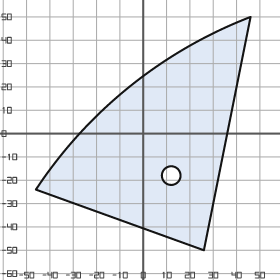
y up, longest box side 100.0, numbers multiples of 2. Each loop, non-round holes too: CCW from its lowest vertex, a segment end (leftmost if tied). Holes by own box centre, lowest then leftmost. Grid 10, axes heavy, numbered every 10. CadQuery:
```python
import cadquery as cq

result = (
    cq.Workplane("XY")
    .moveTo(26.0, -50.0)
    .lineTo(46.0, 50.0)
    .threePointArc((-6.0, 20.0), (-46.0, -24.0))
    .close()
    .moveTo(12.0, -18.0)
    .circle(4.0)
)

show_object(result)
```